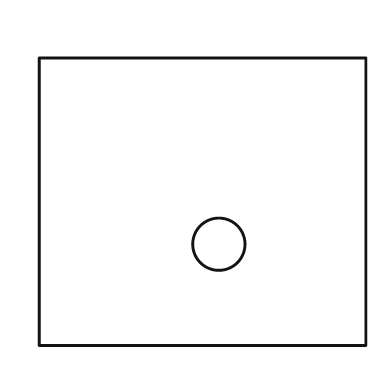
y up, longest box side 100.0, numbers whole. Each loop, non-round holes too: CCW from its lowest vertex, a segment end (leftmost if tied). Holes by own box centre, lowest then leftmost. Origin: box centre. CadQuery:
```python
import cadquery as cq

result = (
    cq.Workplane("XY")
    .moveTo(-50.0, -44.0)
    .lineTo(50.0, -44.0)
    .lineTo(50.0, 44.0)
    .lineTo(-50.0, 44.0)
    .close()
    .moveTo(5.0, -13.0)
    .circle(8.0)
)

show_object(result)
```